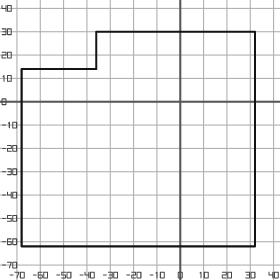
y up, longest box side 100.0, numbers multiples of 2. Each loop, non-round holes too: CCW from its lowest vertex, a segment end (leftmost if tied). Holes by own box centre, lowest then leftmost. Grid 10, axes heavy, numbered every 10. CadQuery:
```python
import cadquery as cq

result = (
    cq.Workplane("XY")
    .moveTo(-68.0, -62.0)
    .lineTo(32.0, -62.0)
    .lineTo(32.0, 30.0)
    .lineTo(-36.0, 30.0)
    .lineTo(-36.0, 14.0)
    .lineTo(-68.0, 14.0)
    .close()
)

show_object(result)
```